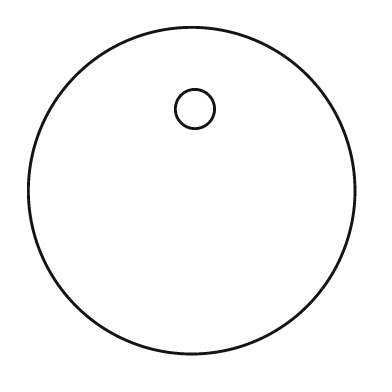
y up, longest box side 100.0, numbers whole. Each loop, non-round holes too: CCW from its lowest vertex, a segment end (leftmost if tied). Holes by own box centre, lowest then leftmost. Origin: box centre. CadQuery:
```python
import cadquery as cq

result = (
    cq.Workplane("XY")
    .moveTo(0.0, 0.0)
    .circle(50.0)
    .moveTo(1.0, 25.0)
    .circle(6.0)
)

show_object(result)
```